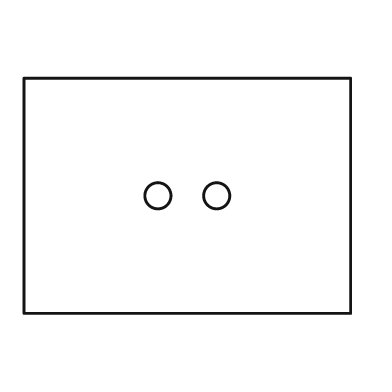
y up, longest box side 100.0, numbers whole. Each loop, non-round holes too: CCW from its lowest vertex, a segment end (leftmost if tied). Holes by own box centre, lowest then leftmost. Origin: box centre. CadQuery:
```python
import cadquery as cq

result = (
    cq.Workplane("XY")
    .moveTo(-50.0, -36.0)
    .lineTo(50.0, -36.0)
    .lineTo(50.0, 36.0)
    .lineTo(-50.0, 36.0)
    .close()
    .moveTo(-9.0, 0.0)
    .circle(4.0)
    .moveTo(9.0, 0.0)
    .circle(4.0)
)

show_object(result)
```